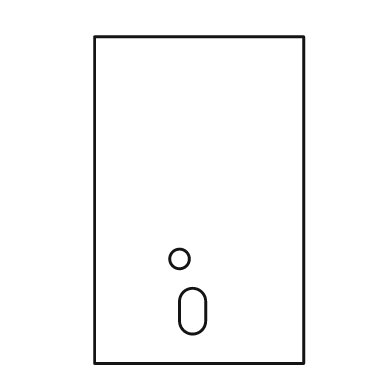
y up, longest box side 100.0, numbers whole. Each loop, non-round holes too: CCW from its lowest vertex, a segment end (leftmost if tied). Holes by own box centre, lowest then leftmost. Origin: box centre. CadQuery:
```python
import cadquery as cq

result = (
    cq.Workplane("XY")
    .moveTo(-32.0, -50.0)
    .lineTo(32.0, -50.0)
    .lineTo(32.0, 50.0)
    .lineTo(-32.0, 50.0)
    .close()
    .moveTo(-6.0, -37.0)
    .threePointArc((-2.0, -41.0), (2.0, -37.0))
    .lineTo(2.0, -31.0)
    .threePointArc((-2.0, -27.0), (-6.0, -31.0))
    .close()
    .moveTo(-6.0, -18.0)
    .circle(3.0)
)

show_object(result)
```